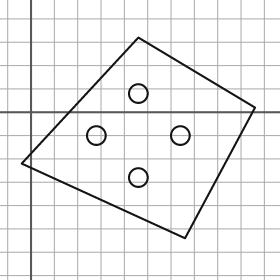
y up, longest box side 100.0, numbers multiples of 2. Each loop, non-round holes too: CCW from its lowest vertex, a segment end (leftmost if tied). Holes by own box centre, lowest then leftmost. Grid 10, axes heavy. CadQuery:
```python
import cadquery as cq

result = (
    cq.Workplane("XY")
    .moveTo(66.0, -54.0)
    .lineTo(96.0, 2.0)
    .lineTo(46.0, 32.0)
    .lineTo(-4.0, -22.0)
    .close()
    .moveTo(46.0, -28.0)
    .circle(4.0)
    .moveTo(28.0, -10.0)
    .circle(4.0)
    .moveTo(64.0, -10.0)
    .circle(4.0)
    .moveTo(46.0, 8.0)
    .circle(4.0)
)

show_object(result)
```